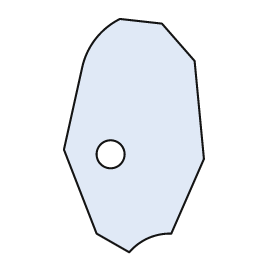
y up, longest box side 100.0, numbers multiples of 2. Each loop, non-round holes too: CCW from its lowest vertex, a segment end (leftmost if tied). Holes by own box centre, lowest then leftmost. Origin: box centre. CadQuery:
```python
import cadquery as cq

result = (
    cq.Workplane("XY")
    .moveTo(-2.0, -50.0)
    .threePointArc((6.0, -44.0), (16.0, -42.0))
    .lineTo(30.0, -10.0)
    .lineTo(26.0, 32.0)
    .lineTo(12.0, 48.0)
    .lineTo(-6.0, 50.0)
    .threePointArc((-16.0, 42.0), (-22.0, 30.0))
    .lineTo(-30.0, -6.0)
    .lineTo(-16.0, -42.0)
    .close()
    .moveTo(-10.0, -8.0)
    .circle(6.0)
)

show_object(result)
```